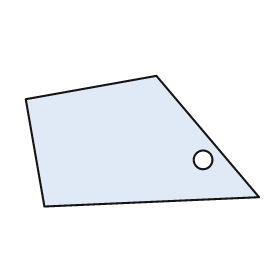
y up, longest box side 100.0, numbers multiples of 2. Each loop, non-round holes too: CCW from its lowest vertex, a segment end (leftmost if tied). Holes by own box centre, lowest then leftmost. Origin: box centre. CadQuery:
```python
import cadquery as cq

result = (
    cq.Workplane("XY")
    .moveTo(-42.0, -28.0)
    .lineTo(50.0, -24.0)
    .lineTo(6.0, 28.0)
    .lineTo(-50.0, 18.0)
    .close()
    .moveTo(26.0, -8.0)
    .circle(4.0)
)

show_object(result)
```